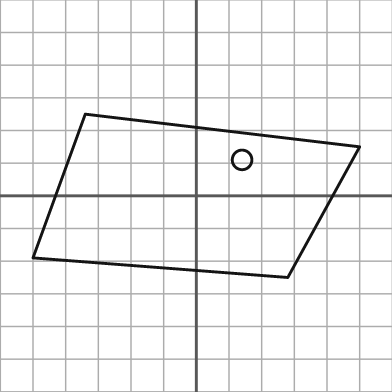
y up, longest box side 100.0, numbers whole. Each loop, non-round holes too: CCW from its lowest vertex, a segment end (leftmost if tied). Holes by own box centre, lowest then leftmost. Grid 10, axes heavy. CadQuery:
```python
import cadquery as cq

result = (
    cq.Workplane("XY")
    .moveTo(28.0, -25.0)
    .lineTo(50.0, 15.0)
    .lineTo(-34.0, 25.0)
    .lineTo(-50.0, -19.0)
    .close()
    .moveTo(14.0, 11.0)
    .circle(3.0)
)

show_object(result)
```